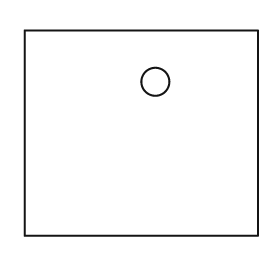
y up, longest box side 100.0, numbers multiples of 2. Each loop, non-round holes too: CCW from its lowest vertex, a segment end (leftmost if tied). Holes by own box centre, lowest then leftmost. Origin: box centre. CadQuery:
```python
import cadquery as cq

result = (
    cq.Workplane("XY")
    .moveTo(-50.0, -44.0)
    .lineTo(50.0, -44.0)
    .lineTo(50.0, 44.0)
    .lineTo(-50.0, 44.0)
    .close()
    .moveTo(6.0, 22.0)
    .circle(6.0)
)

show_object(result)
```